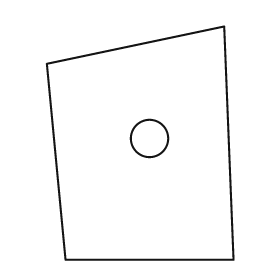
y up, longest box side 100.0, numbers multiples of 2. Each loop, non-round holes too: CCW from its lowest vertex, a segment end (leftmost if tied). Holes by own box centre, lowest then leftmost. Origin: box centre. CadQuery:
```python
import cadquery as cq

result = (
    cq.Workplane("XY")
    .moveTo(-32.0, -50.0)
    .lineTo(40.0, -50.0)
    .lineTo(36.0, 50.0)
    .lineTo(-40.0, 34.0)
    .close()
    .moveTo(4.0, 2.0)
    .circle(8.0)
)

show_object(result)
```